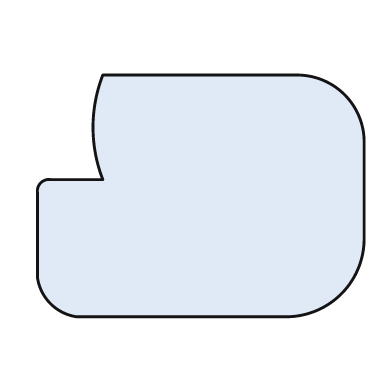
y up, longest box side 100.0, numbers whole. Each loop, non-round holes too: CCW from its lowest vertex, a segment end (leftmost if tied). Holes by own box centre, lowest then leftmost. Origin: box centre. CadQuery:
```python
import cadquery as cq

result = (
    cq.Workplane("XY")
    .moveTo(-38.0, -37.0)
    .lineTo(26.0, -37.0)
    .threePointArc((43.0, -30.0), (50.0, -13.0))
    .lineTo(50.0, 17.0)
    .threePointArc((44.0, 31.0), (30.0, 37.0))
    .lineTo(-30.0, 37.0)
    .threePointArc((-33.0, 21.0), (-30.0, 5.0))
    .lineTo(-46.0, 5.0)
    .threePointArc((-49.0, 4.0), (-50.0, 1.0))
    .lineTo(-50.0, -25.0)
    .threePointArc((-46.0, -33.0), (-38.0, -37.0))
    .close()
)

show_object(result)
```